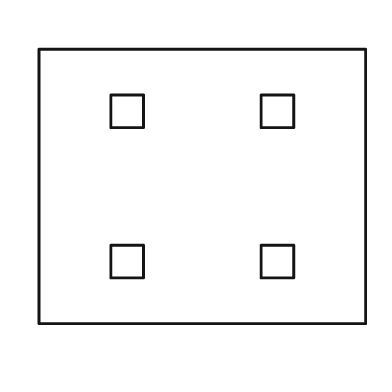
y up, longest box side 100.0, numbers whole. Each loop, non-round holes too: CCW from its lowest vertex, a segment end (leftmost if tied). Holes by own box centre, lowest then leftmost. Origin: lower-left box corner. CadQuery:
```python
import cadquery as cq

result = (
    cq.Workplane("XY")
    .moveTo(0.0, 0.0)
    .lineTo(100.0, 0.0)
    .lineTo(100.0, 84.0)
    .lineTo(0.0, 84.0)
    .close()
    .moveTo(22.0, 14.0)
    .lineTo(32.0, 14.0)
    .lineTo(32.0, 24.0)
    .lineTo(22.0, 24.0)
    .close()
    .moveTo(68.0, 14.0)
    .lineTo(78.0, 14.0)
    .lineTo(78.0, 24.0)
    .lineTo(68.0, 24.0)
    .close()
    .moveTo(22.0, 60.0)
    .lineTo(32.0, 60.0)
    .lineTo(32.0, 70.0)
    .lineTo(22.0, 70.0)
    .close()
    .moveTo(68.0, 60.0)
    .lineTo(78.0, 60.0)
    .lineTo(78.0, 70.0)
    .lineTo(68.0, 70.0)
    .close()
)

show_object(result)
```